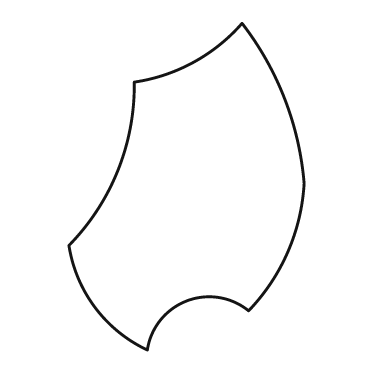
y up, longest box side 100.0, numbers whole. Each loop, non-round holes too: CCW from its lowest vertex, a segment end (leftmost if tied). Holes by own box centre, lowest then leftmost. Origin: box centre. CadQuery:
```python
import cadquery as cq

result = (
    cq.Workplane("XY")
    .moveTo(-12.0, -50.0)
    .threePointArc((0.0, -35.0), (19.0, -38.0))
    .threePointArc((31.0, -20.0), (36.0, 1.0))
    .threePointArc((30.0, 27.0), (17.0, 50.0))
    .threePointArc((2.0, 38.0), (-16.0, 32.0))
    .threePointArc((-21.0, 5.0), (-36.0, -18.0))
    .threePointArc((-28.0, -37.0), (-12.0, -50.0))
    .close()
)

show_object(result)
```